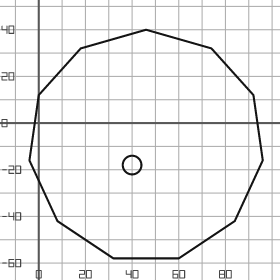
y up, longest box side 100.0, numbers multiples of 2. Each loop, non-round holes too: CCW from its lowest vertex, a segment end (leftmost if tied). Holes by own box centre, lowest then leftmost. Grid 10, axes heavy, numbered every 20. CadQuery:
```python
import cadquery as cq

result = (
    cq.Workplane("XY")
    .moveTo(32.0, -58.0)
    .lineTo(60.0, -58.0)
    .lineTo(84.0, -42.0)
    .lineTo(96.0, -16.0)
    .lineTo(92.0, 12.0)
    .lineTo(74.0, 32.0)
    .lineTo(46.0, 40.0)
    .lineTo(18.0, 32.0)
    .lineTo(0.0, 12.0)
    .lineTo(-4.0, -16.0)
    .lineTo(8.0, -42.0)
    .close()
    .moveTo(40.0, -18.0)
    .circle(4.0)
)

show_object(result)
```